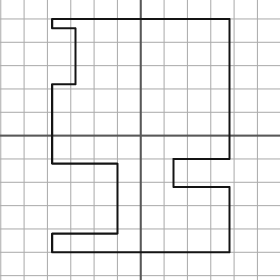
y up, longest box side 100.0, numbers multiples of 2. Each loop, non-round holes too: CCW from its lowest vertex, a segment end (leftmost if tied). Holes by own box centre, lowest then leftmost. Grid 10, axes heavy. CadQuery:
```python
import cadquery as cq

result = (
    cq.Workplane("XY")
    .moveTo(-38.0, -50.0)
    .lineTo(38.0, -50.0)
    .lineTo(38.0, -22.0)
    .lineTo(14.0, -22.0)
    .lineTo(14.0, -10.0)
    .lineTo(38.0, -10.0)
    .lineTo(38.0, 50.0)
    .lineTo(-38.0, 50.0)
    .lineTo(-38.0, 46.0)
    .lineTo(-28.0, 46.0)
    .lineTo(-28.0, 22.0)
    .lineTo(-38.0, 22.0)
    .lineTo(-38.0, -12.0)
    .lineTo(-10.0, -12.0)
    .lineTo(-10.0, -42.0)
    .lineTo(-38.0, -42.0)
    .close()
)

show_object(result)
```